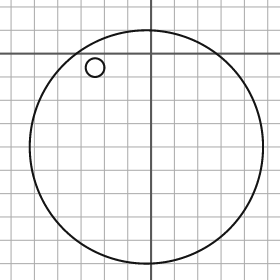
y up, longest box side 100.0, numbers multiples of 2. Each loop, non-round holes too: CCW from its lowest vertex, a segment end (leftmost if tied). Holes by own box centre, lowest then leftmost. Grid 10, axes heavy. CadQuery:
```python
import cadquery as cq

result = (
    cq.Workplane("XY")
    .moveTo(-2.0, -40.0)
    .circle(50.0)
    .moveTo(-24.0, -6.0)
    .circle(4.0)
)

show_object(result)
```